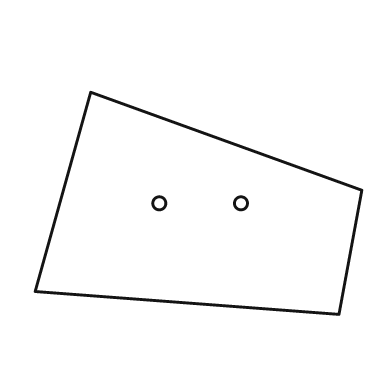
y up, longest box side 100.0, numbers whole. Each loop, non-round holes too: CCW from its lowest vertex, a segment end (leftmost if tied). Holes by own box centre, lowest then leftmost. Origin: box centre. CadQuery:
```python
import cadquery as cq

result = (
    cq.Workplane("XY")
    .moveTo(43.0, -34.0)
    .lineTo(50.0, 4.0)
    .lineTo(-33.0, 34.0)
    .lineTo(-50.0, -27.0)
    .close()
    .moveTo(-12.0, 0.0)
    .circle(2.0)
    .moveTo(13.0, 0.0)
    .circle(2.0)
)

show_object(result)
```